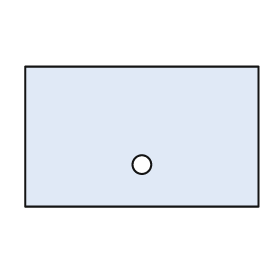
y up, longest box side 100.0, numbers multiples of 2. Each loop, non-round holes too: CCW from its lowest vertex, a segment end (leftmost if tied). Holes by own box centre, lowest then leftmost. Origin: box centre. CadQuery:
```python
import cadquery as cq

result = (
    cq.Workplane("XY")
    .moveTo(-50.0, -30.0)
    .lineTo(50.0, -30.0)
    .lineTo(50.0, 30.0)
    .lineTo(-50.0, 30.0)
    .close()
    .moveTo(0.0, -12.0)
    .circle(4.0)
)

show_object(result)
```